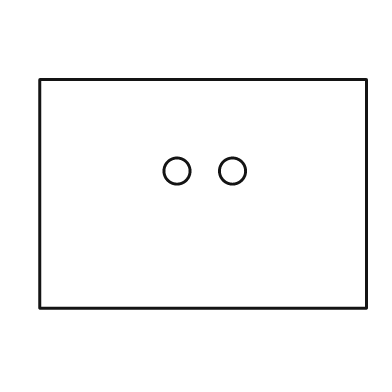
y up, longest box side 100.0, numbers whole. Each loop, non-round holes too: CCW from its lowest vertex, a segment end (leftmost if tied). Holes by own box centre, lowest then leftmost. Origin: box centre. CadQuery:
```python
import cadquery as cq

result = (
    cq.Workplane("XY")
    .moveTo(-50.0, -35.0)
    .lineTo(50.0, -35.0)
    .lineTo(50.0, 35.0)
    .lineTo(-50.0, 35.0)
    .close()
    .moveTo(-8.0, 7.0)
    .circle(4.0)
    .moveTo(9.0, 7.0)
    .circle(4.0)
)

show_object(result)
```